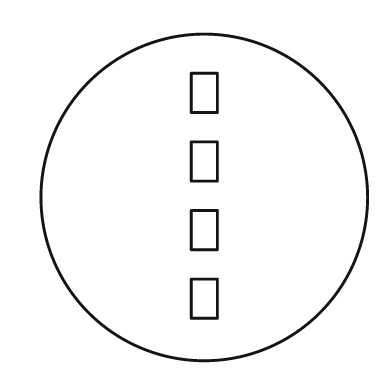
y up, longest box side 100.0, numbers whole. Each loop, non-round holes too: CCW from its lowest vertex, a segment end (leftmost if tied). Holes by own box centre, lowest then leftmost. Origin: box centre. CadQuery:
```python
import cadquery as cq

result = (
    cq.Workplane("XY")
    .moveTo(0.0, 0.0)
    .circle(50.0)
    .moveTo(-4.0, -37.0)
    .lineTo(4.0, -37.0)
    .lineTo(4.0, -25.0)
    .lineTo(-4.0, -25.0)
    .close()
    .moveTo(-4.0, -16.0)
    .lineTo(4.0, -16.0)
    .lineTo(4.0, -4.0)
    .lineTo(-4.0, -4.0)
    .close()
    .moveTo(-4.0, 5.0)
    .lineTo(4.0, 5.0)
    .lineTo(4.0, 17.0)
    .lineTo(-4.0, 17.0)
    .close()
    .moveTo(-4.0, 26.0)
    .lineTo(4.0, 26.0)
    .lineTo(4.0, 38.0)
    .lineTo(-4.0, 38.0)
    .close()
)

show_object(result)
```